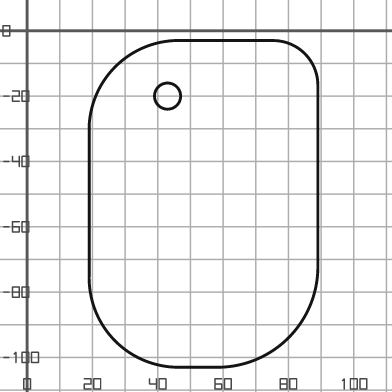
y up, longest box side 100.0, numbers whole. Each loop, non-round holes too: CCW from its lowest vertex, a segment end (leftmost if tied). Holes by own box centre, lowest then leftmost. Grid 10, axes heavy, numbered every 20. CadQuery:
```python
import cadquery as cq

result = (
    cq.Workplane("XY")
    .moveTo(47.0, -103.0)
    .lineTo(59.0, -103.0)
    .threePointArc((80.0, -94.0), (89.0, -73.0))
    .lineTo(89.0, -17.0)
    .threePointArc((85.0, -7.0), (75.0, -3.0))
    .lineTo(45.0, -3.0)
    .threePointArc((27.0, -11.0), (19.0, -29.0))
    .lineTo(19.0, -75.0)
    .threePointArc((27.0, -95.0), (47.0, -103.0))
    .close()
    .moveTo(43.0, -20.0)
    .circle(4.0)
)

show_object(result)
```